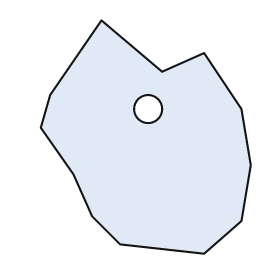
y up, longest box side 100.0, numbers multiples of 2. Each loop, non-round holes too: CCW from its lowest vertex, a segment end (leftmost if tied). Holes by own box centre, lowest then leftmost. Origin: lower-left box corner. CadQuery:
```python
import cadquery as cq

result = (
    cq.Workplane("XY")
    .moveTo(70.0, 0.0)
    .lineTo(86.0, 14.0)
    .lineTo(90.0, 38.0)
    .lineTo(86.0, 62.0)
    .lineTo(70.0, 86.0)
    .lineTo(52.0, 78.0)
    .lineTo(26.0, 100.0)
    .lineTo(4.0, 68.0)
    .lineTo(0.0, 54.0)
    .lineTo(14.0, 34.0)
    .lineTo(22.0, 16.0)
    .lineTo(34.0, 4.0)
    .close()
    .moveTo(46.0, 62.0)
    .circle(6.0)
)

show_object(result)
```